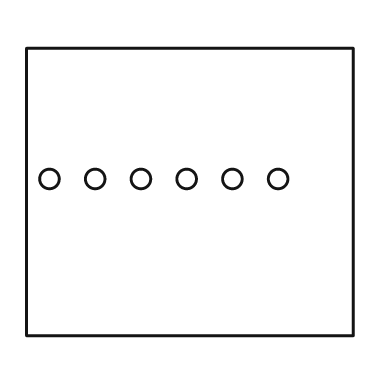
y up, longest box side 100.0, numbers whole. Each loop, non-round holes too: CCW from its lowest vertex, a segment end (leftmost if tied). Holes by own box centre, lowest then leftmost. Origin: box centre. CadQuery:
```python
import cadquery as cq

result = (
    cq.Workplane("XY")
    .moveTo(-50.0, -44.0)
    .lineTo(50.0, -44.0)
    .lineTo(50.0, 44.0)
    .lineTo(-50.0, 44.0)
    .close()
    .moveTo(-43.0, 4.0)
    .circle(3.0)
    .moveTo(-29.0, 4.0)
    .circle(3.0)
    .moveTo(-15.0, 4.0)
    .circle(3.0)
    .moveTo(-1.0, 4.0)
    .circle(3.0)
    .moveTo(13.0, 4.0)
    .circle(3.0)
    .moveTo(27.0, 4.0)
    .circle(3.0)
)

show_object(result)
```